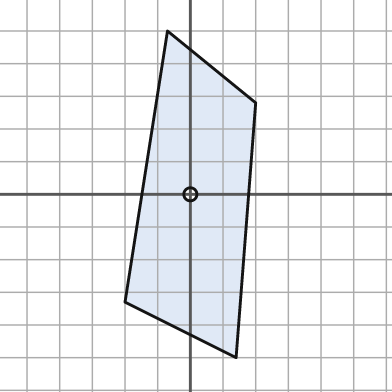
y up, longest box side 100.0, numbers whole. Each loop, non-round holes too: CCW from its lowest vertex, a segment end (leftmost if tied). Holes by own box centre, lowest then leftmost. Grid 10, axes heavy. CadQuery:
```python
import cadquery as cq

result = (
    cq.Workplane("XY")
    .moveTo(14.0, -50.0)
    .lineTo(20.0, 28.0)
    .lineTo(-7.0, 50.0)
    .lineTo(-20.0, -33.0)
    .close()
    .moveTo(0.0, 0.0)
    .circle(2.0)
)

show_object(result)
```